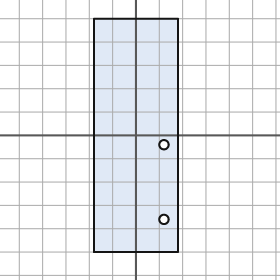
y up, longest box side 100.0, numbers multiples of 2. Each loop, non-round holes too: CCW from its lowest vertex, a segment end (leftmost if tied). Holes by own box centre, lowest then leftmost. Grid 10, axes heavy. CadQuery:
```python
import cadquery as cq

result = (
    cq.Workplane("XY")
    .moveTo(-18.0, -50.0)
    .lineTo(18.0, -50.0)
    .lineTo(18.0, 50.0)
    .lineTo(-18.0, 50.0)
    .close()
    .moveTo(12.0, -36.0)
    .circle(2.0)
    .moveTo(12.0, -4.0)
    .circle(2.0)
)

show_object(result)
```